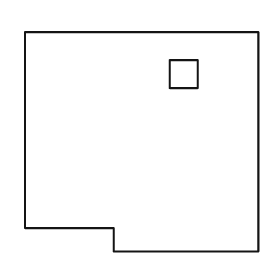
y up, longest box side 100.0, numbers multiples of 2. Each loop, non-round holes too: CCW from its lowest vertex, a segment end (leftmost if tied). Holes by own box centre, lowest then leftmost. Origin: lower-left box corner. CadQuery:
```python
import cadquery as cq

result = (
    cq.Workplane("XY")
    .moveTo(38.0, 0.0)
    .lineTo(100.0, 0.0)
    .lineTo(100.0, 94.0)
    .lineTo(0.0, 94.0)
    .lineTo(0.0, 10.0)
    .lineTo(38.0, 10.0)
    .close()
    .moveTo(62.0, 70.0)
    .lineTo(74.0, 70.0)
    .lineTo(74.0, 82.0)
    .lineTo(62.0, 82.0)
    .close()
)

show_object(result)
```